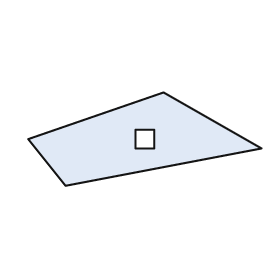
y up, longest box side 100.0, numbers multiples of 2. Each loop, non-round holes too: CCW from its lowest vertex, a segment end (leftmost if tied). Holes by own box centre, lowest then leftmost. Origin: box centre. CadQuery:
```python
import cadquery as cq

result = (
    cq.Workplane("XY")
    .moveTo(-34.0, -20.0)
    .lineTo(50.0, -4.0)
    .lineTo(8.0, 20.0)
    .lineTo(-50.0, 0.0)
    .close()
    .moveTo(-4.0, -4.0)
    .lineTo(4.0, -4.0)
    .lineTo(4.0, 4.0)
    .lineTo(-4.0, 4.0)
    .close()
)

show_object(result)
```